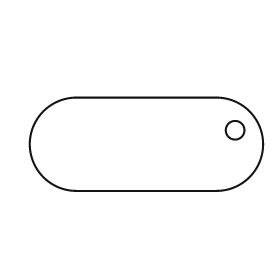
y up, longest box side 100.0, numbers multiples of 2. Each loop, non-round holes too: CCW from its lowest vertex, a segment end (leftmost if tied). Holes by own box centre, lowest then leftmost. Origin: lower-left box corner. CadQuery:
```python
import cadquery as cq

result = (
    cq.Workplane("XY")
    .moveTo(20.0, 0.0)
    .lineTo(80.0, 0.0)
    .threePointArc((100.0, 20.0), (80.0, 40.0))
    .lineTo(20.0, 40.0)
    .threePointArc((0.0, 20.0), (20.0, 0.0))
    .close()
    .moveTo(88.0, 26.0)
    .circle(4.0)
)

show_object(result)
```